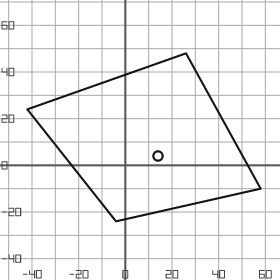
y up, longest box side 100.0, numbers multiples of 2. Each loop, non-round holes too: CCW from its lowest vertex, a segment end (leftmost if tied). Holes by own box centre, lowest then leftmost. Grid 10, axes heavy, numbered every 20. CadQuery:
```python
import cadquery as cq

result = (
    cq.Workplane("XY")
    .moveTo(-4.0, -24.0)
    .lineTo(58.0, -10.0)
    .lineTo(26.0, 48.0)
    .lineTo(-42.0, 24.0)
    .close()
    .moveTo(14.0, 4.0)
    .circle(2.0)
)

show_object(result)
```